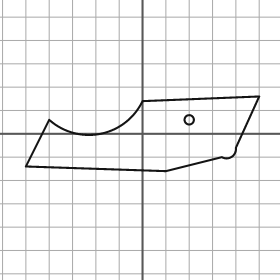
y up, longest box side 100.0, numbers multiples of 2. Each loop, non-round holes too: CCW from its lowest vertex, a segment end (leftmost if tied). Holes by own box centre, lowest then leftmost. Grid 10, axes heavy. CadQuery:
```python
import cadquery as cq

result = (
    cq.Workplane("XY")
    .moveTo(10.0, -16.0)
    .lineTo(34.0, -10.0)
    .threePointArc((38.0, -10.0), (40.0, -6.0))
    .lineTo(50.0, 16.0)
    .lineTo(0.0, 14.0)
    .threePointArc((-18.0, 0.0), (-40.0, 6.0))
    .lineTo(-50.0, -14.0)
    .close()
    .moveTo(20.0, 6.0)
    .circle(2.0)
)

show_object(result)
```